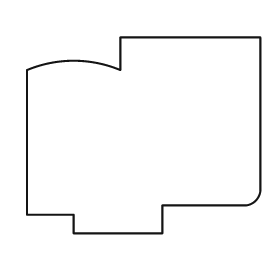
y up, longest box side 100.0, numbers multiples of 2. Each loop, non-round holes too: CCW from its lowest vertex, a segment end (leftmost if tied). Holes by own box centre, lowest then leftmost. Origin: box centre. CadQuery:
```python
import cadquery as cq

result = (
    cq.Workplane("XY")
    .moveTo(-30.0, -42.0)
    .lineTo(8.0, -42.0)
    .lineTo(8.0, -30.0)
    .lineTo(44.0, -30.0)
    .threePointArc((48.0, -28.0), (50.0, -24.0))
    .lineTo(50.0, 42.0)
    .lineTo(-10.0, 42.0)
    .lineTo(-10.0, 28.0)
    .threePointArc((-30.0, 32.0), (-50.0, 28.0))
    .lineTo(-50.0, -34.0)
    .lineTo(-30.0, -34.0)
    .close()
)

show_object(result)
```